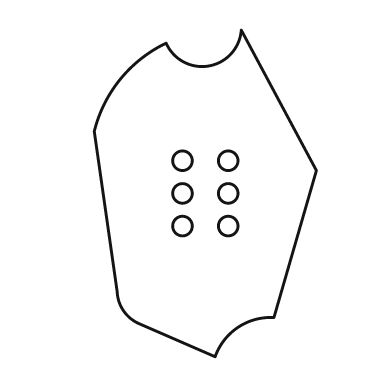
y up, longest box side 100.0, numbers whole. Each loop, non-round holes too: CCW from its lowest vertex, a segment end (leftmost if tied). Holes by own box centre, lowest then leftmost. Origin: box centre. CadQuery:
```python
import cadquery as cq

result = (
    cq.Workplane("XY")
    .moveTo(3.0, -50.0)
    .threePointArc((10.0, -41.0), (21.0, -38.0))
    .lineTo(34.0, 7.0)
    .lineTo(11.0, 50.0)
    .threePointArc((1.0, 39.0), (-12.0, 46.0))
    .threePointArc((-26.0, 35.0), (-34.0, 19.0))
    .lineTo(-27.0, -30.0)
    .threePointArc((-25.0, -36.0), (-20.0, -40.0))
    .close()
    .moveTo(-7.0, -10.0)
    .circle(3.0)
    .moveTo(7.0, -10.0)
    .circle(3.0)
    .moveTo(-7.0, 0.0)
    .circle(3.0)
    .moveTo(7.0, 0.0)
    .circle(3.0)
    .moveTo(-7.0, 10.0)
    .circle(3.0)
    .moveTo(7.0, 10.0)
    .circle(3.0)
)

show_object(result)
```